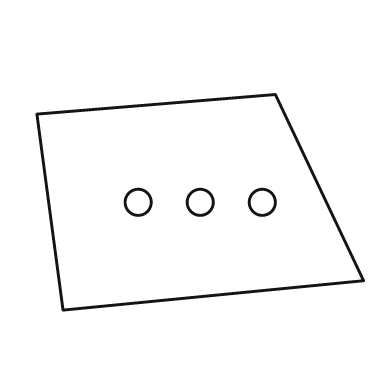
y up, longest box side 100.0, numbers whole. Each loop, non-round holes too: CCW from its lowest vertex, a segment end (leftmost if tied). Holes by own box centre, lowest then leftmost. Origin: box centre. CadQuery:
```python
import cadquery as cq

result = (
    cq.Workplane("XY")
    .moveTo(-42.0, -33.0)
    .lineTo(50.0, -24.0)
    .lineTo(23.0, 33.0)
    .lineTo(-50.0, 27.0)
    .close()
    .moveTo(-19.0, 0.0)
    .circle(4.0)
    .moveTo(0.0, 0.0)
    .circle(4.0)
    .moveTo(19.0, 0.0)
    .circle(4.0)
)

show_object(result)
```